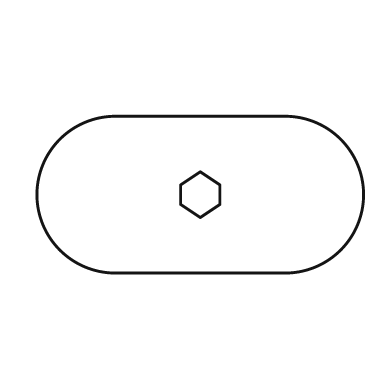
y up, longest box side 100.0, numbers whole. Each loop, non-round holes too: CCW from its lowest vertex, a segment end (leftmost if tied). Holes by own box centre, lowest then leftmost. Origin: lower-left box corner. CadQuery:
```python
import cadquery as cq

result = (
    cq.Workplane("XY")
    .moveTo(24.0, 0.0)
    .lineTo(76.0, 0.0)
    .threePointArc((100.0, 24.0), (76.0, 48.0))
    .lineTo(24.0, 48.0)
    .threePointArc((0.0, 24.0), (24.0, 0.0))
    .close()
    .moveTo(50.0, 17.0)
    .lineTo(56.0, 21.0)
    .lineTo(56.0, 27.0)
    .lineTo(50.0, 31.0)
    .lineTo(44.0, 27.0)
    .lineTo(44.0, 21.0)
    .close()
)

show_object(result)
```